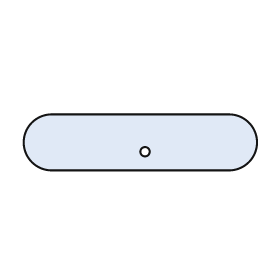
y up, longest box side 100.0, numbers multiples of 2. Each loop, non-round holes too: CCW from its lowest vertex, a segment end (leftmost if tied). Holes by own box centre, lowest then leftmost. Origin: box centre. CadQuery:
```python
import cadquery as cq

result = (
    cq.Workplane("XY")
    .moveTo(-38.0, -12.0)
    .lineTo(38.0, -12.0)
    .threePointArc((50.0, 0.0), (38.0, 12.0))
    .lineTo(-38.0, 12.0)
    .threePointArc((-50.0, 0.0), (-38.0, -12.0))
    .close()
    .moveTo(2.0, -4.0)
    .circle(2.0)
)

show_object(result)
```